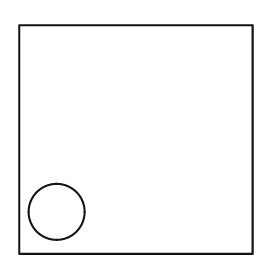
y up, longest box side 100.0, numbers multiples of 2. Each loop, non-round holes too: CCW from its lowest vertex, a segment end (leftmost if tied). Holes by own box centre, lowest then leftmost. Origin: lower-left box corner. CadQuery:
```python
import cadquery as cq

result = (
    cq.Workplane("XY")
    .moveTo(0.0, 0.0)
    .lineTo(100.0, 0.0)
    .lineTo(100.0, 98.0)
    .lineTo(0.0, 98.0)
    .close()
    .moveTo(16.0, 18.0)
    .circle(12.0)
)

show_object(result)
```